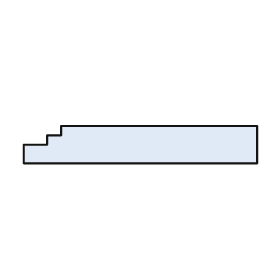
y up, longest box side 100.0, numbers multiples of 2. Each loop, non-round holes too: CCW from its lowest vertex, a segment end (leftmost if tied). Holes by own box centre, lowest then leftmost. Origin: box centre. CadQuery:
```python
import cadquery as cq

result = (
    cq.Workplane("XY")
    .moveTo(-50.0, -8.0)
    .lineTo(50.0, -8.0)
    .lineTo(50.0, 8.0)
    .lineTo(-34.0, 8.0)
    .lineTo(-34.0, 4.0)
    .lineTo(-40.0, 4.0)
    .lineTo(-40.0, 0.0)
    .lineTo(-50.0, 0.0)
    .close()
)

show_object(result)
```